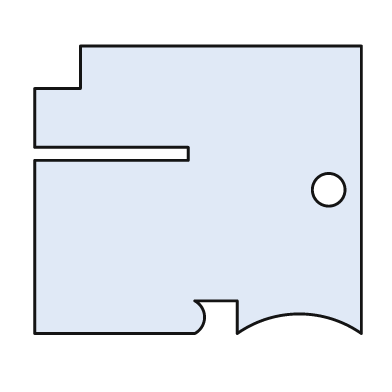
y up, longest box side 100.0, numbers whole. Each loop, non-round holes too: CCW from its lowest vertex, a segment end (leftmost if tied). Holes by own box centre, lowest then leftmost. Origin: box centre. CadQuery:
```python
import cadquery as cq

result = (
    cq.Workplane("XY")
    .moveTo(-50.0, -44.0)
    .lineTo(-1.0, -44.0)
    .threePointArc((2.0, -39.0), (-1.0, -34.0))
    .lineTo(12.0, -34.0)
    .lineTo(12.0, -44.0)
    .threePointArc((31.0, -38.0), (50.0, -44.0))
    .lineTo(50.0, 44.0)
    .lineTo(-36.0, 44.0)
    .lineTo(-36.0, 31.0)
    .lineTo(-50.0, 31.0)
    .lineTo(-50.0, 13.0)
    .lineTo(-3.0, 13.0)
    .lineTo(-3.0, 9.0)
    .lineTo(-50.0, 9.0)
    .close()
    .moveTo(40.0, 0.0)
    .circle(5.0)
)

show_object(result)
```